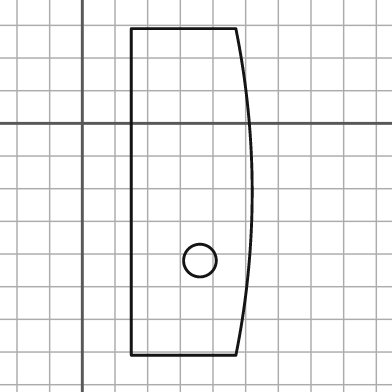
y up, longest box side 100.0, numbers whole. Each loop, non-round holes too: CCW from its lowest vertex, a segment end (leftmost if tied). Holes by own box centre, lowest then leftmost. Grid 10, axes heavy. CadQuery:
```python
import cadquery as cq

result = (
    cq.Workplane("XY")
    .moveTo(15.0, -71.0)
    .lineTo(47.0, -71.0)
    .threePointArc((52.0, -21.0), (47.0, 29.0))
    .lineTo(15.0, 29.0)
    .close()
    .moveTo(36.0, -42.0)
    .circle(5.0)
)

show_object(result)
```